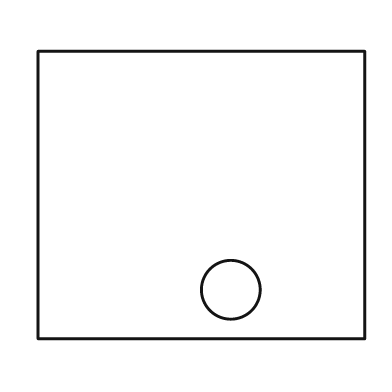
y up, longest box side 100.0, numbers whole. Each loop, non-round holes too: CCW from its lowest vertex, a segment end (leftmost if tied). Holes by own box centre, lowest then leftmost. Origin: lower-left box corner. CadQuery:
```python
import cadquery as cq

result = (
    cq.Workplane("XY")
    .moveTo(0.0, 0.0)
    .lineTo(100.0, 0.0)
    .lineTo(100.0, 88.0)
    .lineTo(0.0, 88.0)
    .close()
    .moveTo(59.0, 15.0)
    .circle(9.0)
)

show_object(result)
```